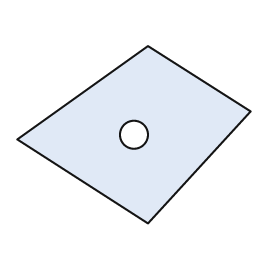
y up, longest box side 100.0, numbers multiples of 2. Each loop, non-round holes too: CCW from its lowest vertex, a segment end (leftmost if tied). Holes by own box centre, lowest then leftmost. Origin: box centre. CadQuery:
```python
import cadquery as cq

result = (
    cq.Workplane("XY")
    .moveTo(6.0, -38.0)
    .lineTo(50.0, 10.0)
    .lineTo(6.0, 38.0)
    .lineTo(-50.0, -2.0)
    .close()
    .moveTo(0.0, 0.0)
    .circle(6.0)
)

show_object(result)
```